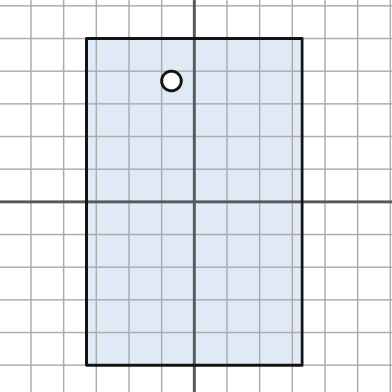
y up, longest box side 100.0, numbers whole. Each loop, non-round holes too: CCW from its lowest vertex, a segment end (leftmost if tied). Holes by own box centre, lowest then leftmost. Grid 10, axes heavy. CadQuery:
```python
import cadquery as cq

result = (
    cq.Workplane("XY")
    .moveTo(-33.0, -50.0)
    .lineTo(33.0, -50.0)
    .lineTo(33.0, 50.0)
    .lineTo(-33.0, 50.0)
    .close()
    .moveTo(-7.0, 37.0)
    .circle(3.0)
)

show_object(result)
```